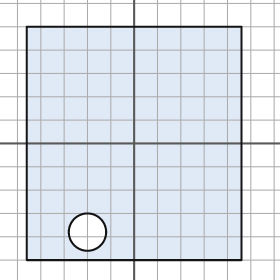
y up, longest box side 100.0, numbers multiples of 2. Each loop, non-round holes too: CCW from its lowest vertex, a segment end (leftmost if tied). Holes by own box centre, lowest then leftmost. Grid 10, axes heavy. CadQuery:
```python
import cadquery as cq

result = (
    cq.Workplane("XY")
    .moveTo(-46.0, -50.0)
    .lineTo(46.0, -50.0)
    .lineTo(46.0, 50.0)
    .lineTo(-46.0, 50.0)
    .close()
    .moveTo(-20.0, -38.0)
    .circle(8.0)
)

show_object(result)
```